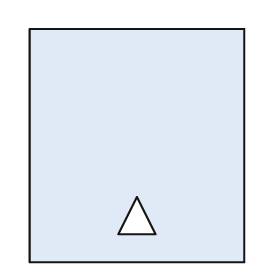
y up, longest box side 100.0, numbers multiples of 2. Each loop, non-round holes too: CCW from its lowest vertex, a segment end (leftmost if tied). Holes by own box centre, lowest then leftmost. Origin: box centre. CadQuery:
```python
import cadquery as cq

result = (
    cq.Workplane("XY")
    .moveTo(-46.0, -50.0)
    .lineTo(46.0, -50.0)
    .lineTo(46.0, 50.0)
    .lineTo(-46.0, 50.0)
    .close()
    .moveTo(-8.0, -38.0)
    .lineTo(8.0, -38.0)
    .lineTo(0.0, -22.0)
    .close()
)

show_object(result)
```